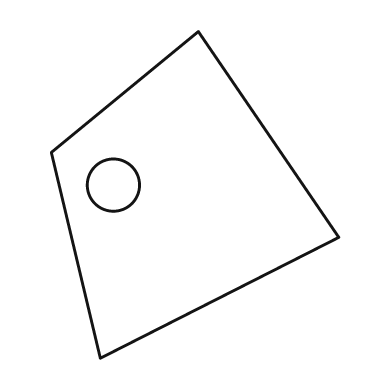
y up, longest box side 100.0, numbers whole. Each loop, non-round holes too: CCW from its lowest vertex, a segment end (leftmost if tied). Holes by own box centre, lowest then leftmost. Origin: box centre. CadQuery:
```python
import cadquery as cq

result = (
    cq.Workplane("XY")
    .moveTo(-29.0, -50.0)
    .lineTo(44.0, -13.0)
    .lineTo(1.0, 50.0)
    .lineTo(-44.0, 13.0)
    .close()
    .moveTo(-25.0, 3.0)
    .circle(8.0)
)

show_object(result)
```